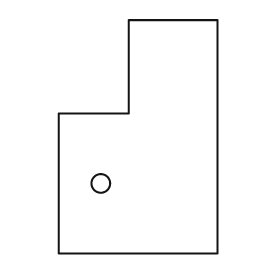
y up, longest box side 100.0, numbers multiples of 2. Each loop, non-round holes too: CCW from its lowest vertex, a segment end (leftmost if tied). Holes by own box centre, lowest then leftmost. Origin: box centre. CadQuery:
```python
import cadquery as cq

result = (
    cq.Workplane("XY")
    .moveTo(-34.0, -50.0)
    .lineTo(34.0, -50.0)
    .lineTo(34.0, 50.0)
    .lineTo(-4.0, 50.0)
    .lineTo(-4.0, 10.0)
    .lineTo(-34.0, 10.0)
    .close()
    .moveTo(-16.0, -20.0)
    .circle(4.0)
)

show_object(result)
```